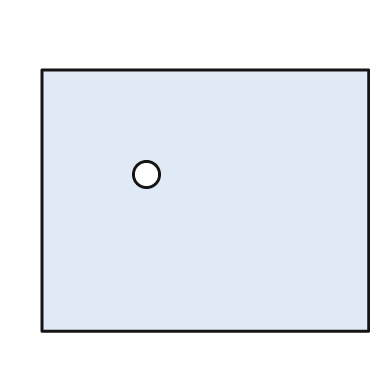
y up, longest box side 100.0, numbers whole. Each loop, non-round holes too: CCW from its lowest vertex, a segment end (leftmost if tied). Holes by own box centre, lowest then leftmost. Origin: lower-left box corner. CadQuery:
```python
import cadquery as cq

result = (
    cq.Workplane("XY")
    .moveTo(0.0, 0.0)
    .lineTo(100.0, 0.0)
    .lineTo(100.0, 80.0)
    .lineTo(0.0, 80.0)
    .close()
    .moveTo(32.0, 48.0)
    .circle(4.0)
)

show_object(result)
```